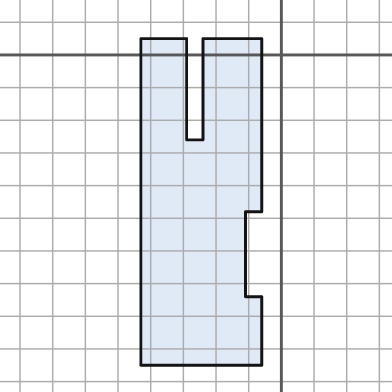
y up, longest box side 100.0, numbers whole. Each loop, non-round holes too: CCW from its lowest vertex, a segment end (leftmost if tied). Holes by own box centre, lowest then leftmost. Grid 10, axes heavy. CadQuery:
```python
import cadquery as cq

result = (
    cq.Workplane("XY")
    .moveTo(-43.0, -95.0)
    .lineTo(-6.0, -95.0)
    .lineTo(-6.0, -74.0)
    .lineTo(-11.0, -74.0)
    .lineTo(-11.0, -48.0)
    .lineTo(-6.0, -48.0)
    .lineTo(-6.0, 5.0)
    .lineTo(-24.0, 5.0)
    .lineTo(-24.0, -26.0)
    .lineTo(-29.0, -26.0)
    .lineTo(-29.0, 5.0)
    .lineTo(-43.0, 5.0)
    .close()
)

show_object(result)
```